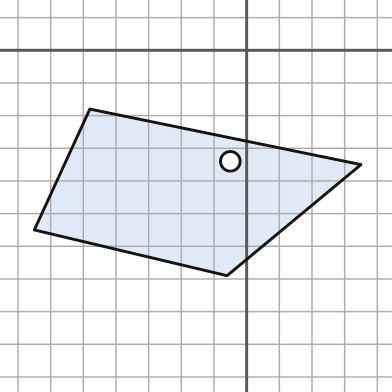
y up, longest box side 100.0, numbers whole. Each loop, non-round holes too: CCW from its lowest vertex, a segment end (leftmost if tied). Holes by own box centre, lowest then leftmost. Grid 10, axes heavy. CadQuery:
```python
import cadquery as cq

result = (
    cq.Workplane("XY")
    .moveTo(-6.0, -69.0)
    .lineTo(35.0, -35.0)
    .lineTo(-48.0, -18.0)
    .lineTo(-65.0, -55.0)
    .close()
    .moveTo(-5.0, -34.0)
    .circle(3.0)
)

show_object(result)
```